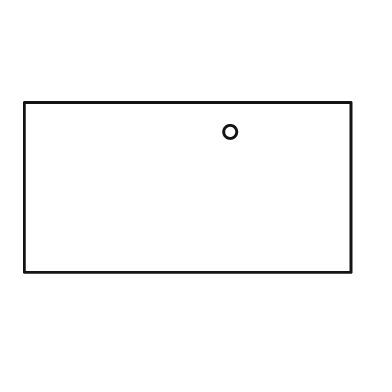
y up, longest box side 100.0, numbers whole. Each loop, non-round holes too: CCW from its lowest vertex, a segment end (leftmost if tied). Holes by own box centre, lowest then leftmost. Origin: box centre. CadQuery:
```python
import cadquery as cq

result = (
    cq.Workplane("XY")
    .moveTo(-50.0, -26.0)
    .lineTo(50.0, -26.0)
    .lineTo(50.0, 26.0)
    .lineTo(-50.0, 26.0)
    .close()
    .moveTo(13.0, 17.0)
    .circle(2.0)
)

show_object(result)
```